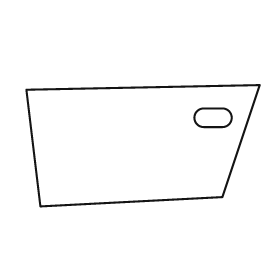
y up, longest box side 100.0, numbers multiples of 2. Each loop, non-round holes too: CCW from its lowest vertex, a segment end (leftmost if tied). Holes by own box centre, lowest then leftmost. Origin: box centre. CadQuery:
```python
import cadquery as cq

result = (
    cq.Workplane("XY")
    .moveTo(-44.0, -26.0)
    .lineTo(34.0, -22.0)
    .lineTo(50.0, 26.0)
    .lineTo(-50.0, 24.0)
    .close()
    .moveTo(26.0, 8.0)
    .lineTo(34.0, 8.0)
    .threePointArc((38.0, 12.0), (34.0, 16.0))
    .lineTo(26.0, 16.0)
    .threePointArc((22.0, 12.0), (26.0, 8.0))
    .close()
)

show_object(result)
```